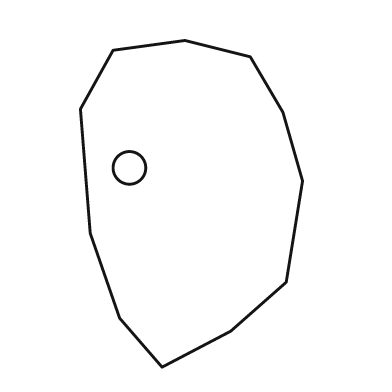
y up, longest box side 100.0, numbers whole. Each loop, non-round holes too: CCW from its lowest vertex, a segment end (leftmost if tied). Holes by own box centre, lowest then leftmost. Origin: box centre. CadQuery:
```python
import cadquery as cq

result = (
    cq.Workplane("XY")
    .moveTo(-9.0, -50.0)
    .lineTo(12.0, -39.0)
    .lineTo(29.0, -24.0)
    .lineTo(34.0, 7.0)
    .lineTo(28.0, 28.0)
    .lineTo(18.0, 45.0)
    .lineTo(-2.0, 50.0)
    .lineTo(-24.0, 47.0)
    .lineTo(-34.0, 29.0)
    .lineTo(-31.0, -9.0)
    .lineTo(-22.0, -35.0)
    .close()
    .moveTo(-19.0, 11.0)
    .circle(5.0)
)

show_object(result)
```